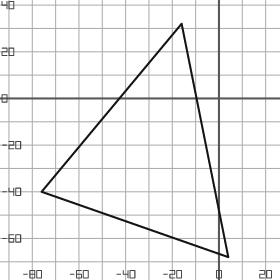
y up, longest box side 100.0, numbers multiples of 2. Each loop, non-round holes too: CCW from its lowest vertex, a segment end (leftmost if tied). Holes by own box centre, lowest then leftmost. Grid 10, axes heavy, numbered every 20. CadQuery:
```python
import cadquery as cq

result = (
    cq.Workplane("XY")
    .moveTo(4.0, -68.0)
    .lineTo(-16.0, 32.0)
    .lineTo(-76.0, -40.0)
    .close()
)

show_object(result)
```